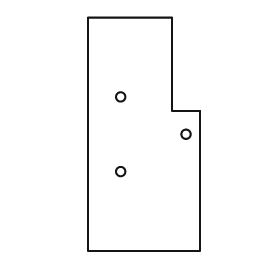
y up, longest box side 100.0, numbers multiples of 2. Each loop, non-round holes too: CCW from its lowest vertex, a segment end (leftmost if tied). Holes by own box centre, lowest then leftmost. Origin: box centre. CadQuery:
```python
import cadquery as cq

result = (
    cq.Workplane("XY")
    .moveTo(-24.0, -50.0)
    .lineTo(24.0, -50.0)
    .lineTo(24.0, 10.0)
    .lineTo(12.0, 10.0)
    .lineTo(12.0, 50.0)
    .lineTo(-24.0, 50.0)
    .close()
    .moveTo(-10.0, -16.0)
    .circle(2.0)
    .moveTo(18.0, 0.0)
    .circle(2.0)
    .moveTo(-10.0, 16.0)
    .circle(2.0)
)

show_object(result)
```